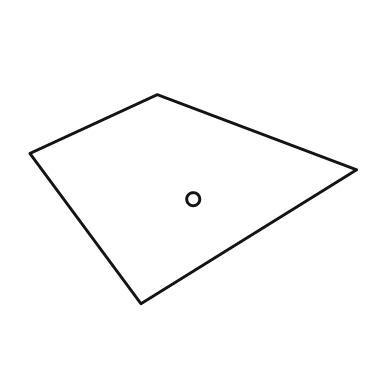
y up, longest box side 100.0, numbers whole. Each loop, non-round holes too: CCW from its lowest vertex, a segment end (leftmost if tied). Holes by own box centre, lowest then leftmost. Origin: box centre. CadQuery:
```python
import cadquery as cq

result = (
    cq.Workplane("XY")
    .moveTo(-16.0, -32.0)
    .lineTo(50.0, 9.0)
    .lineTo(-11.0, 32.0)
    .lineTo(-50.0, 14.0)
    .close()
    .moveTo(0.0, 0.0)
    .circle(2.0)
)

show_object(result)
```